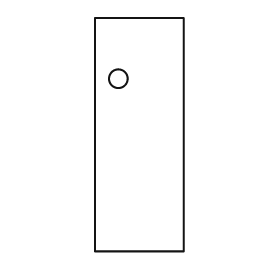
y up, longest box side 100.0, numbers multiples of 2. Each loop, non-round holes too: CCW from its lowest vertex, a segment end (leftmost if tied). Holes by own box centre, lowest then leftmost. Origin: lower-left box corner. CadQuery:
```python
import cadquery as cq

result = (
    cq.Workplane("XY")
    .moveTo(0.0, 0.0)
    .lineTo(38.0, 0.0)
    .lineTo(38.0, 100.0)
    .lineTo(0.0, 100.0)
    .close()
    .moveTo(10.0, 74.0)
    .circle(4.0)
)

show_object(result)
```